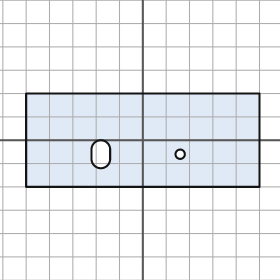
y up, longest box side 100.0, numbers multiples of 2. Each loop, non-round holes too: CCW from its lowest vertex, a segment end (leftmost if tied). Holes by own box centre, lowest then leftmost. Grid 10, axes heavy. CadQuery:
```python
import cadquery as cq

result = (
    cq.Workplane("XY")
    .moveTo(-50.0, -20.0)
    .lineTo(50.0, -20.0)
    .lineTo(50.0, 20.0)
    .lineTo(-50.0, 20.0)
    .close()
    .moveTo(-22.0, -8.0)
    .threePointArc((-18.0, -12.0), (-14.0, -8.0))
    .lineTo(-14.0, -4.0)
    .threePointArc((-18.0, 0.0), (-22.0, -4.0))
    .close()
    .moveTo(16.0, -6.0)
    .circle(2.0)
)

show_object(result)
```